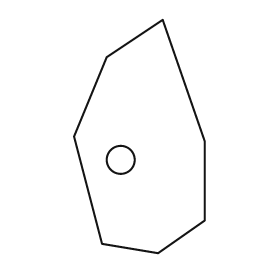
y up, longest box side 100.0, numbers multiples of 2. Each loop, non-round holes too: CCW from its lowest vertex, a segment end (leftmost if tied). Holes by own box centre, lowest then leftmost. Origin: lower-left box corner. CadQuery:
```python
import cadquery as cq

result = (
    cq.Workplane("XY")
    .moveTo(36.0, 0.0)
    .lineTo(56.0, 14.0)
    .lineTo(56.0, 48.0)
    .lineTo(38.0, 100.0)
    .lineTo(14.0, 84.0)
    .lineTo(0.0, 50.0)
    .lineTo(12.0, 4.0)
    .close()
    .moveTo(20.0, 40.0)
    .circle(6.0)
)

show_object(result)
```